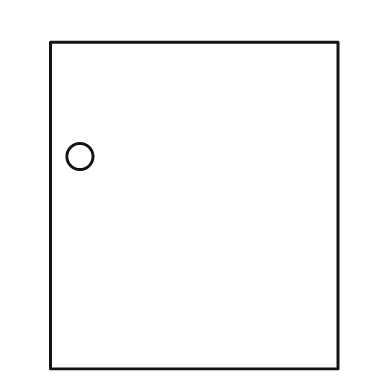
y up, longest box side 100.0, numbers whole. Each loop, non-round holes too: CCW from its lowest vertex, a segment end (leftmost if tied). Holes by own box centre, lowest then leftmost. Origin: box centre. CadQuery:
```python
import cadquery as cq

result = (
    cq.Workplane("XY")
    .moveTo(-44.0, -50.0)
    .lineTo(44.0, -50.0)
    .lineTo(44.0, 50.0)
    .lineTo(-44.0, 50.0)
    .close()
    .moveTo(-35.0, 15.0)
    .circle(4.0)
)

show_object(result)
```